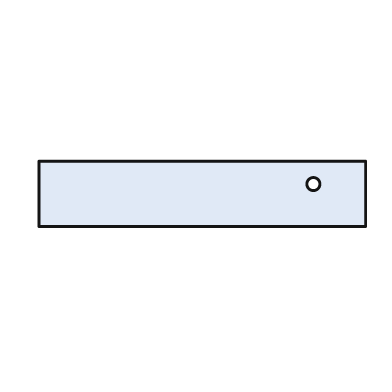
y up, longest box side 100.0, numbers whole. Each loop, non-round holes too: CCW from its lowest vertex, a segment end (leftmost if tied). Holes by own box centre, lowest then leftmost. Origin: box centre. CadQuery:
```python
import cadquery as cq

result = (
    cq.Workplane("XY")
    .moveTo(-50.0, -10.0)
    .lineTo(50.0, -10.0)
    .lineTo(50.0, 10.0)
    .lineTo(-50.0, 10.0)
    .close()
    .moveTo(34.0, 3.0)
    .circle(2.0)
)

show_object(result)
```